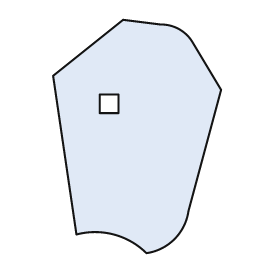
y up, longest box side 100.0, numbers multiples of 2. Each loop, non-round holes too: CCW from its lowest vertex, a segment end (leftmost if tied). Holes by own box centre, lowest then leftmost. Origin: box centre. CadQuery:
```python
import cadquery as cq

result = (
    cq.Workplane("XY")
    .moveTo(4.0, -50.0)
    .threePointArc((16.0, -44.0), (22.0, -32.0))
    .lineTo(36.0, 20.0)
    .lineTo(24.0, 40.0)
    .threePointArc((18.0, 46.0), (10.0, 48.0))
    .lineTo(-6.0, 50.0)
    .lineTo(-36.0, 26.0)
    .lineTo(-26.0, -42.0)
    .threePointArc((-10.0, -42.0), (4.0, -50.0))
    .close()
    .moveTo(-16.0, 10.0)
    .lineTo(-8.0, 10.0)
    .lineTo(-8.0, 18.0)
    .lineTo(-16.0, 18.0)
    .close()
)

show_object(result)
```